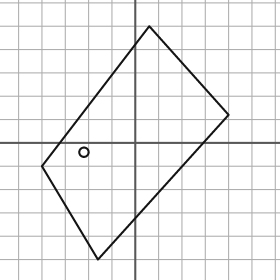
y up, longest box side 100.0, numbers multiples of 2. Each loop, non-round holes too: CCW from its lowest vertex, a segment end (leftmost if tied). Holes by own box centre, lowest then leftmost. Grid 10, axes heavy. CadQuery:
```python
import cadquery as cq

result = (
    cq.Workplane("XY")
    .moveTo(-16.0, -50.0)
    .lineTo(40.0, 12.0)
    .lineTo(6.0, 50.0)
    .lineTo(-40.0, -10.0)
    .close()
    .moveTo(-22.0, -4.0)
    .circle(2.0)
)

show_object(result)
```